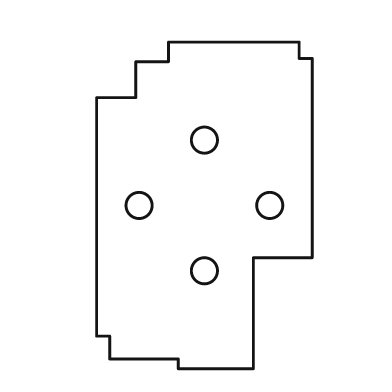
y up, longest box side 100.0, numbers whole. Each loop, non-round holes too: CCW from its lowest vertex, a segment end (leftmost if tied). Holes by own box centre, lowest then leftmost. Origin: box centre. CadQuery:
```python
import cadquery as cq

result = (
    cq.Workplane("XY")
    .moveTo(-8.0, -50.0)
    .lineTo(15.0, -50.0)
    .lineTo(15.0, -16.0)
    .lineTo(33.0, -16.0)
    .lineTo(33.0, 45.0)
    .lineTo(29.0, 45.0)
    .lineTo(29.0, 50.0)
    .lineTo(-11.0, 50.0)
    .lineTo(-11.0, 44.0)
    .lineTo(-21.0, 44.0)
    .lineTo(-21.0, 33.0)
    .lineTo(-33.0, 33.0)
    .lineTo(-33.0, -40.0)
    .lineTo(-29.0, -40.0)
    .lineTo(-29.0, -47.0)
    .lineTo(-8.0, -47.0)
    .close()
    .moveTo(0.0, -20.0)
    .circle(4.0)
    .moveTo(-20.0, 0.0)
    .circle(4.0)
    .moveTo(20.0, 0.0)
    .circle(4.0)
    .moveTo(0.0, 20.0)
    .circle(4.0)
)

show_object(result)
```